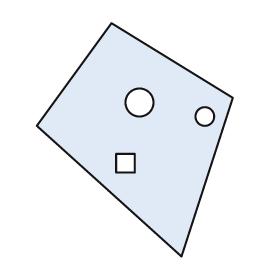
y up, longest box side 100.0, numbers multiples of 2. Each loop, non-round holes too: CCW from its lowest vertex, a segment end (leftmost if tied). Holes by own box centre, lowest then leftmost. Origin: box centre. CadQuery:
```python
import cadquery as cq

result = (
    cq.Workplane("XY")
    .moveTo(20.0, -50.0)
    .lineTo(42.0, 18.0)
    .lineTo(-10.0, 50.0)
    .lineTo(-42.0, 6.0)
    .close()
    .moveTo(-8.0, -14.0)
    .lineTo(0.0, -14.0)
    .lineTo(0.0, -6.0)
    .lineTo(-8.0, -6.0)
    .close()
    .moveTo(30.0, 10.0)
    .circle(4.0)
    .moveTo(2.0, 16.0)
    .circle(6.0)
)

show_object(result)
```